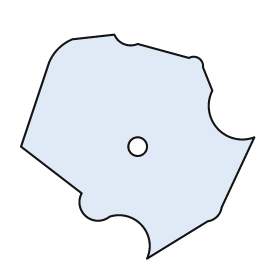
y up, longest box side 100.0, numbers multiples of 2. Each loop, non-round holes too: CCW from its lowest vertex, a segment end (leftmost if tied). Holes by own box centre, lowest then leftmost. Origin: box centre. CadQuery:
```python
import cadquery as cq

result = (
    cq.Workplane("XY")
    .moveTo(4.0, -48.0)
    .lineTo(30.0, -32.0)
    .threePointArc((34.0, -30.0), (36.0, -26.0))
    .lineTo(50.0, 4.0)
    .threePointArc((34.0, 8.0), (32.0, 24.0))
    .lineTo(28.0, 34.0)
    .threePointArc((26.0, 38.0), (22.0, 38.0))
    .lineTo(0.0, 44.0)
    .threePointArc((-6.0, 44.0), (-10.0, 48.0))
    .lineTo(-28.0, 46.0)
    .threePointArc((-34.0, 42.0), (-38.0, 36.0))
    .lineTo(-50.0, 0.0)
    .lineTo(-24.0, -20.0)
    .threePointArc((-22.0, -30.0), (-12.0, -30.0))
    .threePointArc((2.0, -34.0), (4.0, -48.0))
    .close()
    .moveTo(0.0, 0.0)
    .circle(4.0)
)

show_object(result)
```